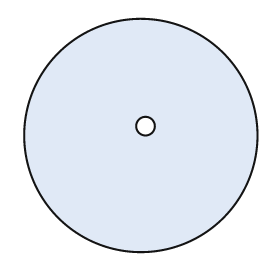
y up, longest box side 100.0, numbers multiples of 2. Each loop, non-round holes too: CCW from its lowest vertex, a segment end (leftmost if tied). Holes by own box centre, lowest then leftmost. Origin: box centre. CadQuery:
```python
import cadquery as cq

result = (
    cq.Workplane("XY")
    .moveTo(0.0, 0.0)
    .circle(50.0)
    .moveTo(2.0, 4.0)
    .circle(4.0)
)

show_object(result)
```